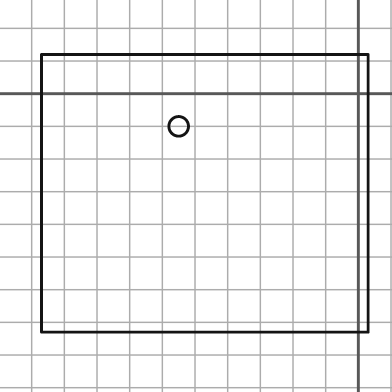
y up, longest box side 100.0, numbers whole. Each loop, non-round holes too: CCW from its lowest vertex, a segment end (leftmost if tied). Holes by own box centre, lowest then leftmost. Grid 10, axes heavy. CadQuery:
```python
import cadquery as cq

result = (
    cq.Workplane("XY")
    .moveTo(-97.0, -73.0)
    .lineTo(3.0, -73.0)
    .lineTo(3.0, 12.0)
    .lineTo(-97.0, 12.0)
    .close()
    .moveTo(-55.0, -10.0)
    .circle(3.0)
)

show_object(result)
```